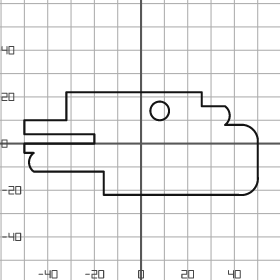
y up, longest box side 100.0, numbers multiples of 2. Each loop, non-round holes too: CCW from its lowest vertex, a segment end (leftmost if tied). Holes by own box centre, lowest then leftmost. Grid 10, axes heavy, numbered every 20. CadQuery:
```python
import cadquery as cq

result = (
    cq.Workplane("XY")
    .moveTo(-16.0, -22.0)
    .lineTo(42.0, -22.0)
    .threePointArc((48.0, -20.0), (50.0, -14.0))
    .lineTo(50.0, 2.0)
    .threePointArc((48.0, 6.0), (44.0, 8.0))
    .lineTo(36.0, 8.0)
    .threePointArc((38.0, 12.0), (36.0, 16.0))
    .lineTo(26.0, 16.0)
    .lineTo(26.0, 22.0)
    .lineTo(-32.0, 22.0)
    .lineTo(-32.0, 10.0)
    .lineTo(-50.0, 10.0)
    .lineTo(-50.0, 4.0)
    .lineTo(-20.0, 4.0)
    .lineTo(-20.0, 0.0)
    .lineTo(-50.0, 0.0)
    .lineTo(-50.0, -4.0)
    .lineTo(-46.0, -4.0)
    .threePointArc((-48.0, -8.0), (-46.0, -12.0))
    .lineTo(-16.0, -12.0)
    .close()
    .moveTo(8.0, 14.0)
    .circle(4.0)
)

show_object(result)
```